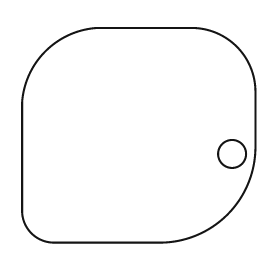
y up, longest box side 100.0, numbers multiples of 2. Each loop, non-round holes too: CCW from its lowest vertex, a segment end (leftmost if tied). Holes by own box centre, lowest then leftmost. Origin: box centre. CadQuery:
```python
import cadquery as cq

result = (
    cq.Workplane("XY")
    .moveTo(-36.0, -46.0)
    .lineTo(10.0, -46.0)
    .threePointArc((38.0, -34.0), (50.0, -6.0))
    .lineTo(50.0, 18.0)
    .threePointArc((42.0, 38.0), (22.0, 46.0))
    .lineTo(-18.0, 46.0)
    .threePointArc((-40.0, 36.0), (-50.0, 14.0))
    .lineTo(-50.0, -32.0)
    .threePointArc((-46.0, -42.0), (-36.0, -46.0))
    .close()
    .moveTo(40.0, -8.0)
    .circle(6.0)
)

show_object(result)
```